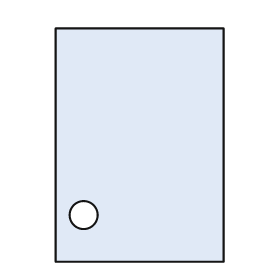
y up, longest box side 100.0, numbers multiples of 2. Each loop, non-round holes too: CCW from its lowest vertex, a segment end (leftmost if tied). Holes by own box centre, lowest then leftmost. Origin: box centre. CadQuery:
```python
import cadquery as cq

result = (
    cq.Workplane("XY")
    .moveTo(-36.0, -50.0)
    .lineTo(36.0, -50.0)
    .lineTo(36.0, 50.0)
    .lineTo(-36.0, 50.0)
    .close()
    .moveTo(-24.0, -30.0)
    .circle(6.0)
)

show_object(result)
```